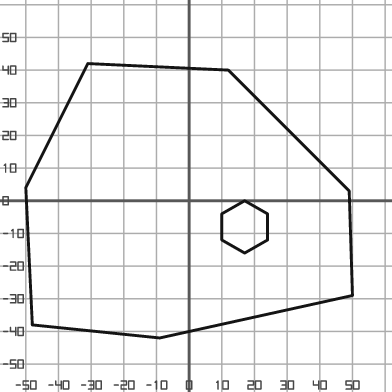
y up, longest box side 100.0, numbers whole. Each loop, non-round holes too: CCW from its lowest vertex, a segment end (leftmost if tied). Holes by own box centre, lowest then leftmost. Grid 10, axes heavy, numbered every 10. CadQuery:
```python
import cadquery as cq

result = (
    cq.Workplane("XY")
    .moveTo(-9.0, -42.0)
    .lineTo(50.0, -29.0)
    .lineTo(49.0, 3.0)
    .lineTo(12.0, 40.0)
    .lineTo(-31.0, 42.0)
    .lineTo(-50.0, 4.0)
    .lineTo(-48.0, -38.0)
    .close()
    .moveTo(17.0, -16.0)
    .lineTo(24.0, -12.0)
    .lineTo(24.0, -4.0)
    .lineTo(17.0, 0.0)
    .lineTo(10.0, -4.0)
    .lineTo(10.0, -12.0)
    .close()
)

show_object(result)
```